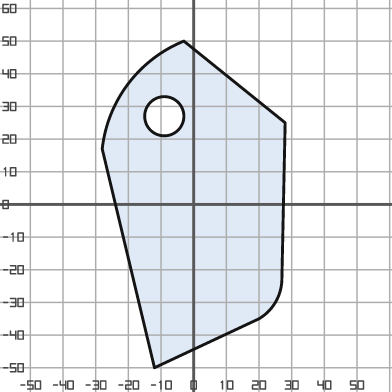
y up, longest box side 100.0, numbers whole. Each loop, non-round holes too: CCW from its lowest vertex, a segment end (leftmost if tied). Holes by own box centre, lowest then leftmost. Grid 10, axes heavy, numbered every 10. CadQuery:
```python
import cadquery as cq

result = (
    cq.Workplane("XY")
    .moveTo(-12.0, -50.0)
    .lineTo(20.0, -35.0)
    .threePointArc((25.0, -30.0), (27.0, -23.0))
    .lineTo(28.0, 25.0)
    .lineTo(-3.0, 50.0)
    .threePointArc((-20.0, 37.0), (-28.0, 17.0))
    .close()
    .moveTo(-9.0, 27.0)
    .circle(6.0)
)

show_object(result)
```